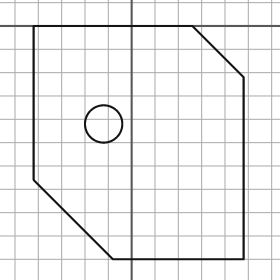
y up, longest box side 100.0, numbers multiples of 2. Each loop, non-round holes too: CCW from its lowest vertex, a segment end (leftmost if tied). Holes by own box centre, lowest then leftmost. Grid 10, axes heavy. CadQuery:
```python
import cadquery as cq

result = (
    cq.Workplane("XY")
    .moveTo(-8.0, -100.0)
    .lineTo(48.0, -100.0)
    .lineTo(48.0, -22.0)
    .lineTo(26.0, 0.0)
    .lineTo(-42.0, 0.0)
    .lineTo(-42.0, -66.0)
    .close()
    .moveTo(-12.0, -42.0)
    .circle(8.0)
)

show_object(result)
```